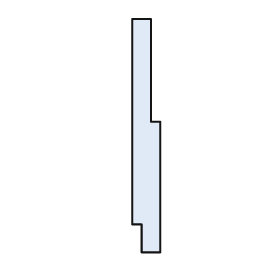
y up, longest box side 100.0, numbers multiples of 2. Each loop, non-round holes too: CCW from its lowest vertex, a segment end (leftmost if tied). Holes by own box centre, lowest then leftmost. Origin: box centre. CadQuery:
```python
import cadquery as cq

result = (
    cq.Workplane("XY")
    .moveTo(-2.0, -50.0)
    .lineTo(6.0, -50.0)
    .lineTo(6.0, 6.0)
    .lineTo(2.0, 6.0)
    .lineTo(2.0, 50.0)
    .lineTo(-6.0, 50.0)
    .lineTo(-6.0, -38.0)
    .lineTo(-2.0, -38.0)
    .close()
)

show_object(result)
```